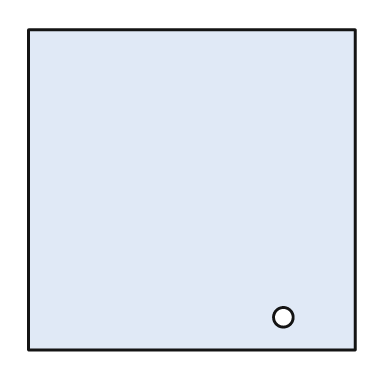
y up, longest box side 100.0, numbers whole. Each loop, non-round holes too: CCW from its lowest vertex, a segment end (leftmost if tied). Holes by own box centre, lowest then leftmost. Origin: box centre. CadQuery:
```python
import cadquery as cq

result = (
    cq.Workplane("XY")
    .moveTo(-50.0, -49.0)
    .lineTo(50.0, -49.0)
    .lineTo(50.0, 49.0)
    .lineTo(-50.0, 49.0)
    .close()
    .moveTo(28.0, -39.0)
    .circle(3.0)
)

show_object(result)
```